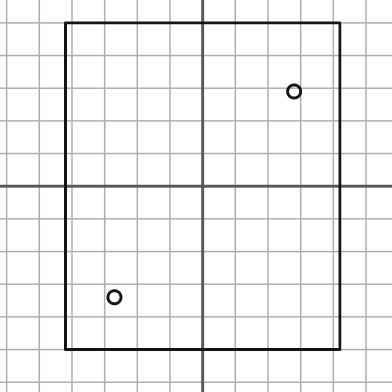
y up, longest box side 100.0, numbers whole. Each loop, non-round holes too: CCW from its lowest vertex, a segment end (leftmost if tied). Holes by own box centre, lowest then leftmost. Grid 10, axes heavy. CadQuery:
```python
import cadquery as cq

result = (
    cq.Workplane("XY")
    .moveTo(-42.0, -50.0)
    .lineTo(42.0, -50.0)
    .lineTo(42.0, 50.0)
    .lineTo(-42.0, 50.0)
    .close()
    .moveTo(-27.0, -34.0)
    .circle(2.0)
    .moveTo(28.0, 29.0)
    .circle(2.0)
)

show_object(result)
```